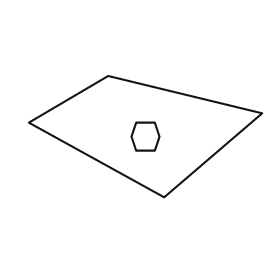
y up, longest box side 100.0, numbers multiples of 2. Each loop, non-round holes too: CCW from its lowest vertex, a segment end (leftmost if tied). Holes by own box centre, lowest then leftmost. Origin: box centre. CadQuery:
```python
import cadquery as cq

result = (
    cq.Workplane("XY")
    .moveTo(8.0, -26.0)
    .lineTo(50.0, 10.0)
    .lineTo(-16.0, 26.0)
    .lineTo(-50.0, 6.0)
    .close()
    .moveTo(-4.0, -6.0)
    .lineTo(4.0, -6.0)
    .lineTo(6.0, 0.0)
    .lineTo(4.0, 6.0)
    .lineTo(-4.0, 6.0)
    .lineTo(-6.0, 0.0)
    .close()
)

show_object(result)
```